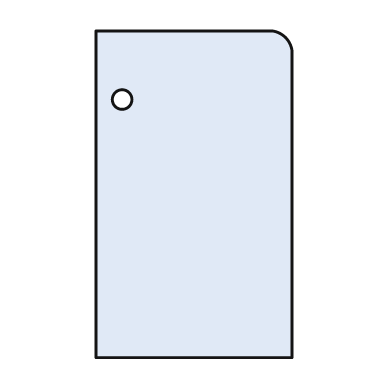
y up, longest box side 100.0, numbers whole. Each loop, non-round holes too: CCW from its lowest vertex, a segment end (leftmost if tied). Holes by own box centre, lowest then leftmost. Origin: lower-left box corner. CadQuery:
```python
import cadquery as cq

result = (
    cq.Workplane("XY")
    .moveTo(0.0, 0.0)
    .lineTo(60.0, 0.0)
    .lineTo(60.0, 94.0)
    .threePointArc((58.0, 98.0), (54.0, 100.0))
    .lineTo(0.0, 100.0)
    .close()
    .moveTo(8.0, 79.0)
    .circle(3.0)
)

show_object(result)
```